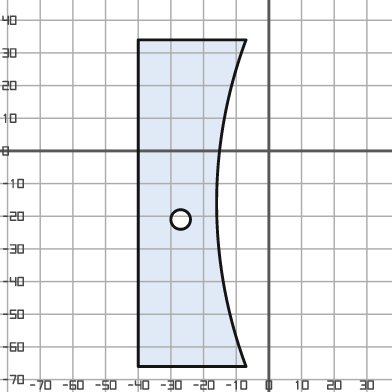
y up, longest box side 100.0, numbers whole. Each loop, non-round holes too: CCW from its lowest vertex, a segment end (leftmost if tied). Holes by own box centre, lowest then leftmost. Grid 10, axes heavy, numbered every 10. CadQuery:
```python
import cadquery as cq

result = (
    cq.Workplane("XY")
    .moveTo(-40.0, -66.0)
    .lineTo(-7.0, -66.0)
    .threePointArc((-16.0, -16.0), (-7.0, 34.0))
    .lineTo(-40.0, 34.0)
    .close()
    .moveTo(-27.0, -21.0)
    .circle(3.0)
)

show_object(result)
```